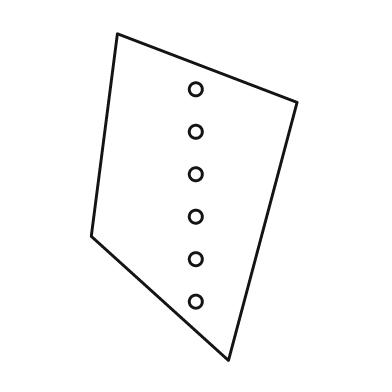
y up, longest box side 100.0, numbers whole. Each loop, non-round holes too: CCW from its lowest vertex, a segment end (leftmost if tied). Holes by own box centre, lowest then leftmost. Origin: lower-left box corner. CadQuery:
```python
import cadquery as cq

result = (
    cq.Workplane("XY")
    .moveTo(42.0, 0.0)
    .lineTo(63.0, 79.0)
    .lineTo(8.0, 100.0)
    .lineTo(0.0, 38.0)
    .close()
    .moveTo(32.0, 18.0)
    .circle(2.0)
    .moveTo(32.0, 31.0)
    .circle(2.0)
    .moveTo(32.0, 44.0)
    .circle(2.0)
    .moveTo(32.0, 57.0)
    .circle(2.0)
    .moveTo(32.0, 70.0)
    .circle(2.0)
    .moveTo(32.0, 83.0)
    .circle(2.0)
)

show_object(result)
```